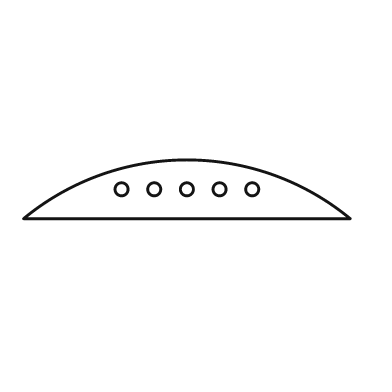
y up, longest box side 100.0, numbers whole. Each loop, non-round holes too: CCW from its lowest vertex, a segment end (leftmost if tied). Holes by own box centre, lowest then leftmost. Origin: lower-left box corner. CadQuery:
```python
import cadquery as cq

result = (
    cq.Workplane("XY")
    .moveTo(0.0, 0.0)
    .lineTo(100.0, 0.0)
    .threePointArc((50.0, 18.0), (0.0, 0.0))
    .close()
    .moveTo(30.0, 9.0)
    .circle(2.0)
    .moveTo(40.0, 9.0)
    .circle(2.0)
    .moveTo(50.0, 9.0)
    .circle(2.0)
    .moveTo(60.0, 9.0)
    .circle(2.0)
    .moveTo(70.0, 9.0)
    .circle(2.0)
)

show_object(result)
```